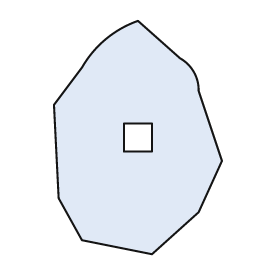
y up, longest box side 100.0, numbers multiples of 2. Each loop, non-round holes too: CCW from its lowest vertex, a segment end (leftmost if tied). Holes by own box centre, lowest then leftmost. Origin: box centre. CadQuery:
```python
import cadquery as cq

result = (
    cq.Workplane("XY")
    .moveTo(6.0, -50.0)
    .lineTo(26.0, -32.0)
    .lineTo(36.0, -10.0)
    .lineTo(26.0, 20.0)
    .threePointArc((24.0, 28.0), (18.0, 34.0))
    .lineTo(0.0, 50.0)
    .threePointArc((-14.0, 42.0), (-24.0, 30.0))
    .lineTo(-36.0, 14.0)
    .lineTo(-34.0, -26.0)
    .lineTo(-24.0, -44.0)
    .close()
    .moveTo(-6.0, -6.0)
    .lineTo(6.0, -6.0)
    .lineTo(6.0, 6.0)
    .lineTo(-6.0, 6.0)
    .close()
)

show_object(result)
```